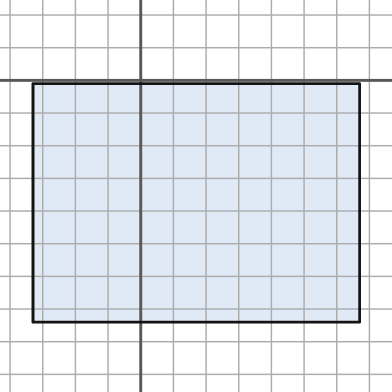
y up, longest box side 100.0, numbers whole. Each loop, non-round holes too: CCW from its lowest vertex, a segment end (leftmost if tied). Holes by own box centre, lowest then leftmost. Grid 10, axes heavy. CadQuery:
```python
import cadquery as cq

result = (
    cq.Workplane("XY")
    .moveTo(-33.0, -74.0)
    .lineTo(67.0, -74.0)
    .lineTo(67.0, -1.0)
    .lineTo(-33.0, -1.0)
    .close()
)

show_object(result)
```